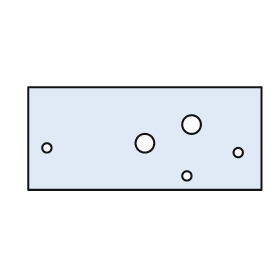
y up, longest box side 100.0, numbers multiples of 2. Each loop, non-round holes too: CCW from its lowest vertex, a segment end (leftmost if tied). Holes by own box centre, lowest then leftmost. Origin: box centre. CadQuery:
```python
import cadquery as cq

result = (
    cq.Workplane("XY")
    .moveTo(-50.0, -22.0)
    .lineTo(50.0, -22.0)
    .lineTo(50.0, 22.0)
    .lineTo(-50.0, 22.0)
    .close()
    .moveTo(18.0, -16.0)
    .circle(2.0)
    .moveTo(40.0, -6.0)
    .circle(2.0)
    .moveTo(-42.0, -4.0)
    .circle(2.0)
    .moveTo(0.0, -2.0)
    .circle(4.0)
    .moveTo(20.0, 6.0)
    .circle(4.0)
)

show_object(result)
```